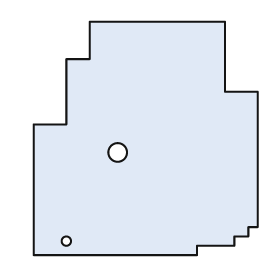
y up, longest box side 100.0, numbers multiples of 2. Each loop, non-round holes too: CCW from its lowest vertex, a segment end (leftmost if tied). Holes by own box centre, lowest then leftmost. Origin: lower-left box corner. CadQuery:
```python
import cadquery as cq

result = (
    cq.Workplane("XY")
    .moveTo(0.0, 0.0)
    .lineTo(70.0, 0.0)
    .lineTo(70.0, 4.0)
    .lineTo(86.0, 4.0)
    .lineTo(86.0, 8.0)
    .lineTo(92.0, 8.0)
    .lineTo(92.0, 12.0)
    .lineTo(96.0, 12.0)
    .lineTo(96.0, 70.0)
    .lineTo(82.0, 70.0)
    .lineTo(82.0, 100.0)
    .lineTo(24.0, 100.0)
    .lineTo(24.0, 84.0)
    .lineTo(14.0, 84.0)
    .lineTo(14.0, 56.0)
    .lineTo(0.0, 56.0)
    .close()
    .moveTo(14.0, 6.0)
    .circle(2.0)
    .moveTo(36.0, 44.0)
    .circle(4.0)
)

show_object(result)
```